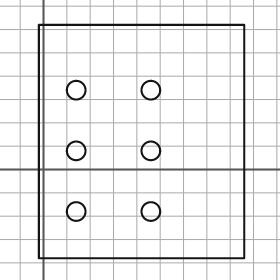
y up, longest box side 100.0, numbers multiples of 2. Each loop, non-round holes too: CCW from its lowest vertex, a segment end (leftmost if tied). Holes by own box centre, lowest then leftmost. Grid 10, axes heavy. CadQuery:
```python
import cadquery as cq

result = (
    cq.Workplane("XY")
    .moveTo(-2.0, -38.0)
    .lineTo(86.0, -38.0)
    .lineTo(86.0, 62.0)
    .lineTo(-2.0, 62.0)
    .close()
    .moveTo(14.0, -18.0)
    .circle(4.0)
    .moveTo(46.0, -18.0)
    .circle(4.0)
    .moveTo(14.0, 8.0)
    .circle(4.0)
    .moveTo(46.0, 8.0)
    .circle(4.0)
    .moveTo(14.0, 34.0)
    .circle(4.0)
    .moveTo(46.0, 34.0)
    .circle(4.0)
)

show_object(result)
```